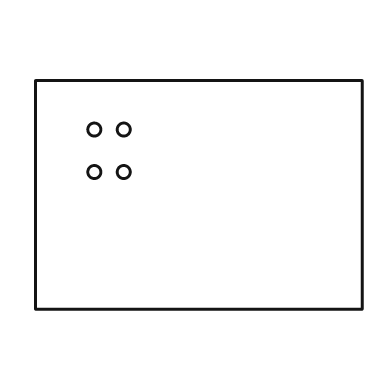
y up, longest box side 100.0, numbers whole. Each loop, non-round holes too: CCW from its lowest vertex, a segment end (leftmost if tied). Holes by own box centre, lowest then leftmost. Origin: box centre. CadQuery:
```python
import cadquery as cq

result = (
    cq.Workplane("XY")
    .moveTo(-50.0, -35.0)
    .lineTo(50.0, -35.0)
    .lineTo(50.0, 35.0)
    .lineTo(-50.0, 35.0)
    .close()
    .moveTo(-32.0, 7.0)
    .circle(2.0)
    .moveTo(-23.0, 7.0)
    .circle(2.0)
    .moveTo(-32.0, 20.0)
    .circle(2.0)
    .moveTo(-23.0, 20.0)
    .circle(2.0)
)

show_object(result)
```